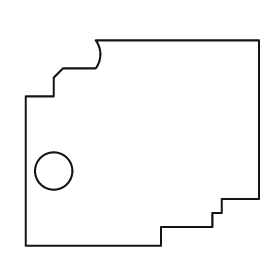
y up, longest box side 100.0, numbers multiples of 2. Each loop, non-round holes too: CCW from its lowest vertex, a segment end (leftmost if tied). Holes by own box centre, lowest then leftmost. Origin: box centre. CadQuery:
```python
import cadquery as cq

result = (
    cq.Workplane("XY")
    .moveTo(-50.0, -44.0)
    .lineTo(8.0, -44.0)
    .lineTo(8.0, -36.0)
    .lineTo(30.0, -36.0)
    .lineTo(30.0, -30.0)
    .lineTo(34.0, -30.0)
    .lineTo(34.0, -24.0)
    .lineTo(50.0, -24.0)
    .lineTo(50.0, 44.0)
    .lineTo(-20.0, 44.0)
    .threePointArc((-18.0, 38.0), (-20.0, 32.0))
    .lineTo(-34.0, 32.0)
    .lineTo(-38.0, 28.0)
    .lineTo(-38.0, 20.0)
    .lineTo(-50.0, 20.0)
    .close()
    .moveTo(-38.0, -12.0)
    .circle(8.0)
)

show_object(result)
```